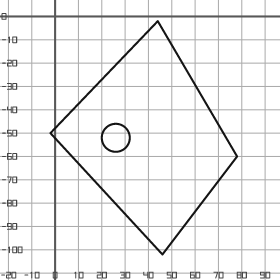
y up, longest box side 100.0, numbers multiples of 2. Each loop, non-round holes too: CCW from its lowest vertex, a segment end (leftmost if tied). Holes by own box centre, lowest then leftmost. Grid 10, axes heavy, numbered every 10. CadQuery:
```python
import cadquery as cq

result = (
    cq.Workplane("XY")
    .moveTo(46.0, -102.0)
    .lineTo(78.0, -60.0)
    .lineTo(44.0, -2.0)
    .lineTo(-2.0, -50.0)
    .close()
    .moveTo(26.0, -52.0)
    .circle(6.0)
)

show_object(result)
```